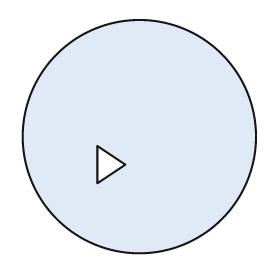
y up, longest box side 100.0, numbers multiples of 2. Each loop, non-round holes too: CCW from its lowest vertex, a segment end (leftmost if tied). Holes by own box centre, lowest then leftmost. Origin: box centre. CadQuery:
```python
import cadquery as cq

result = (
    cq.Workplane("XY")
    .moveTo(0.0, 0.0)
    .circle(50.0)
    .moveTo(-18.0, -20.0)
    .lineTo(-6.0, -12.0)
    .lineTo(-18.0, -4.0)
    .close()
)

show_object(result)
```